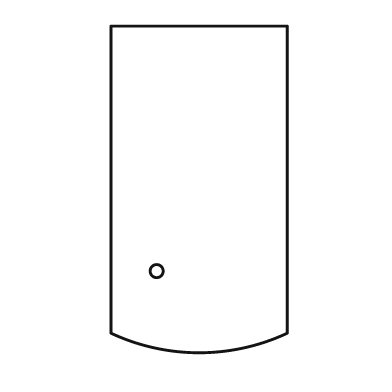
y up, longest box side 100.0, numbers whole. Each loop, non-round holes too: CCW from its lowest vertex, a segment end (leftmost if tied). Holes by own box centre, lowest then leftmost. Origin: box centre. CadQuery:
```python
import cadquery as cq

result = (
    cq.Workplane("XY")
    .moveTo(-27.0, -44.0)
    .threePointArc((0.0, -50.0), (27.0, -44.0))
    .lineTo(27.0, 50.0)
    .lineTo(-27.0, 50.0)
    .close()
    .moveTo(-13.0, -25.0)
    .circle(2.0)
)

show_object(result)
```